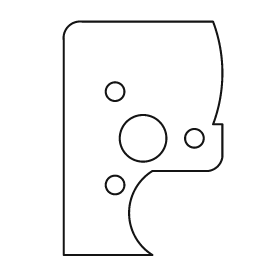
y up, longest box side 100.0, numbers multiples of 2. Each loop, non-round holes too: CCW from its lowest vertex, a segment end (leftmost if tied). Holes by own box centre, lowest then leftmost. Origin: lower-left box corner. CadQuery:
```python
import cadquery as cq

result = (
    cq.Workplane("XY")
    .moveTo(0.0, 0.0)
    .lineTo(38.0, 0.0)
    .threePointArc((28.0, 18.0), (38.0, 36.0))
    .lineTo(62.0, 36.0)
    .threePointArc((66.0, 38.0), (68.0, 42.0))
    .lineTo(68.0, 56.0)
    .lineTo(64.0, 56.0)
    .threePointArc((68.0, 78.0), (64.0, 100.0))
    .lineTo(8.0, 100.0)
    .threePointArc((2.0, 98.0), (0.0, 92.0))
    .close()
    .moveTo(22.0, 30.0)
    .circle(4.0)
    .moveTo(34.0, 50.0)
    .circle(10.0)
    .moveTo(56.0, 50.0)
    .circle(4.0)
    .moveTo(22.0, 70.0)
    .circle(4.0)
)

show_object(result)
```